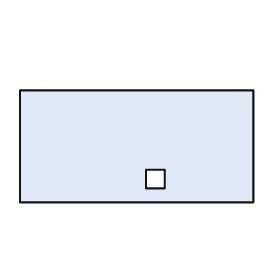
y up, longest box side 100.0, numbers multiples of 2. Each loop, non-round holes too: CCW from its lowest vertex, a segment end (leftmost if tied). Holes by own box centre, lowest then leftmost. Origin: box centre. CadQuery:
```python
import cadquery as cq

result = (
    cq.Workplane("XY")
    .moveTo(-50.0, -24.0)
    .lineTo(50.0, -24.0)
    .lineTo(50.0, 24.0)
    .lineTo(-50.0, 24.0)
    .close()
    .moveTo(4.0, -18.0)
    .lineTo(12.0, -18.0)
    .lineTo(12.0, -10.0)
    .lineTo(4.0, -10.0)
    .close()
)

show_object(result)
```